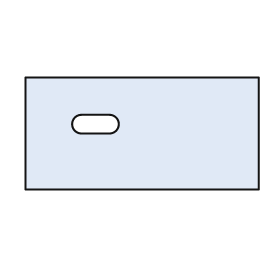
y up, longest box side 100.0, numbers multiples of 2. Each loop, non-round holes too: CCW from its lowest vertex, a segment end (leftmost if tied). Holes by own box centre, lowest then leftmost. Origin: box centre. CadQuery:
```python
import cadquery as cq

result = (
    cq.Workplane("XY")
    .moveTo(-50.0, -24.0)
    .lineTo(50.0, -24.0)
    .lineTo(50.0, 24.0)
    .lineTo(-50.0, 24.0)
    .close()
    .moveTo(-26.0, 0.0)
    .lineTo(-14.0, 0.0)
    .threePointArc((-10.0, 4.0), (-14.0, 8.0))
    .lineTo(-26.0, 8.0)
    .threePointArc((-30.0, 4.0), (-26.0, 0.0))
    .close()
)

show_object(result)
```